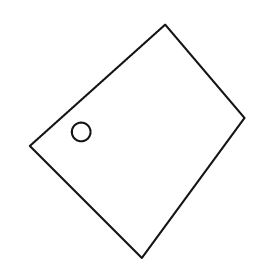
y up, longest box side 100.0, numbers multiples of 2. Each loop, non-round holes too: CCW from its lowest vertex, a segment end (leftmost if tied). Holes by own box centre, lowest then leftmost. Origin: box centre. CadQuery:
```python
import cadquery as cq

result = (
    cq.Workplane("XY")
    .moveTo(2.0, -50.0)
    .lineTo(46.0, 10.0)
    .lineTo(12.0, 50.0)
    .lineTo(-46.0, -2.0)
    .close()
    .moveTo(-24.0, 4.0)
    .circle(4.0)
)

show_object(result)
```